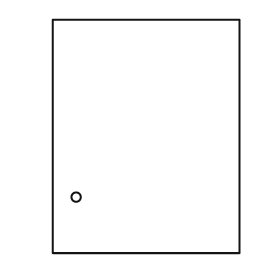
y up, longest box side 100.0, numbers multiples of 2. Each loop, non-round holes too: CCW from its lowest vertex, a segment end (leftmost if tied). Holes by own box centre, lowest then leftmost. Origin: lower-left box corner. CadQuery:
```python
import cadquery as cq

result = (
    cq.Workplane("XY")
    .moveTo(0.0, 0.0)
    .lineTo(80.0, 0.0)
    .lineTo(80.0, 100.0)
    .lineTo(0.0, 100.0)
    .close()
    .moveTo(10.0, 24.0)
    .circle(2.0)
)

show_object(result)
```